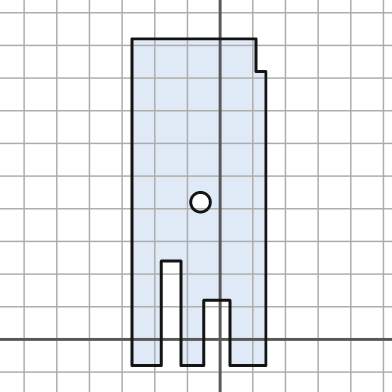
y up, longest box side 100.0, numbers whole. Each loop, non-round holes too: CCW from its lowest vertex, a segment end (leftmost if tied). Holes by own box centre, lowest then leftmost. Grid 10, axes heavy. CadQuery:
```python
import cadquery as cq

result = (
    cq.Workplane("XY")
    .moveTo(-27.0, -8.0)
    .lineTo(-18.0, -8.0)
    .lineTo(-18.0, 24.0)
    .lineTo(-12.0, 24.0)
    .lineTo(-12.0, -8.0)
    .lineTo(-5.0, -8.0)
    .lineTo(-5.0, 12.0)
    .lineTo(3.0, 12.0)
    .lineTo(3.0, -8.0)
    .lineTo(14.0, -8.0)
    .lineTo(14.0, 82.0)
    .lineTo(11.0, 82.0)
    .lineTo(11.0, 92.0)
    .lineTo(-27.0, 92.0)
    .close()
    .moveTo(-6.0, 42.0)
    .circle(3.0)
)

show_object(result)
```